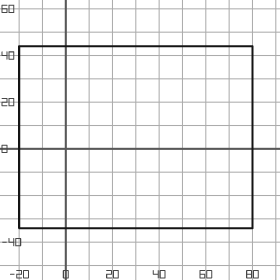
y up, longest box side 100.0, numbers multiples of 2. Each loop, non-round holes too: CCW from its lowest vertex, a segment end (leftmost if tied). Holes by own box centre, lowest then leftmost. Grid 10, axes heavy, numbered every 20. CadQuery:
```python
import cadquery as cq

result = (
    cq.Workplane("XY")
    .moveTo(-20.0, -34.0)
    .lineTo(80.0, -34.0)
    .lineTo(80.0, 44.0)
    .lineTo(-20.0, 44.0)
    .close()
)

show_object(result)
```